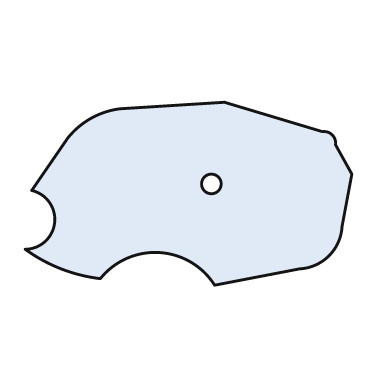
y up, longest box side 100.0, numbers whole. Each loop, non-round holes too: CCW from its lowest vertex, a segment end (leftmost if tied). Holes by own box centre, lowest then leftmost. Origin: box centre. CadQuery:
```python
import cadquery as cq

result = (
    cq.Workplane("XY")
    .moveTo(8.0, -28.0)
    .lineTo(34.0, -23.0)
    .threePointArc((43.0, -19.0), (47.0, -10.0))
    .lineTo(50.0, 6.0)
    .lineTo(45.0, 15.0)
    .threePointArc((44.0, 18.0), (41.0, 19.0))
    .lineTo(11.0, 28.0)
    .lineTo(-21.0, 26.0)
    .threePointArc((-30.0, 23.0), (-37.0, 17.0))
    .lineTo(-48.0, 1.0)
    .threePointArc((-41.0, -9.0), (-50.0, -17.0))
    .threePointArc((-39.0, -23.0), (-27.0, -26.0))
    .threePointArc((-9.0, -18.0), (8.0, -28.0))
    .close()
    .moveTo(7.0, 3.0)
    .circle(3.0)
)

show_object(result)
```